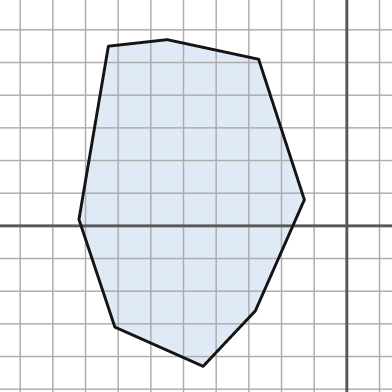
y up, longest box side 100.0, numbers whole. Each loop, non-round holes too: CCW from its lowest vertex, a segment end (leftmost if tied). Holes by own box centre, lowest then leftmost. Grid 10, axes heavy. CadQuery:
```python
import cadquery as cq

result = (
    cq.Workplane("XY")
    .moveTo(-44.0, -43.0)
    .lineTo(-28.0, -26.0)
    .lineTo(-13.0, 8.0)
    .lineTo(-27.0, 51.0)
    .lineTo(-55.0, 57.0)
    .lineTo(-73.0, 55.0)
    .lineTo(-82.0, 2.0)
    .lineTo(-71.0, -31.0)
    .close()
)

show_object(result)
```